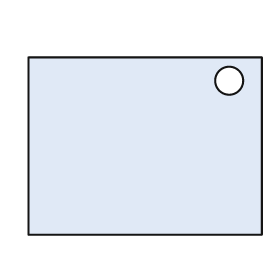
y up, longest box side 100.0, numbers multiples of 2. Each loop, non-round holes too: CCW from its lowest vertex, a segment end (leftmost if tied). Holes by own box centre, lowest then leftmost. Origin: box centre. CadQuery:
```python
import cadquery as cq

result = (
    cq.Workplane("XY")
    .moveTo(-50.0, -38.0)
    .lineTo(50.0, -38.0)
    .lineTo(50.0, 38.0)
    .lineTo(-50.0, 38.0)
    .close()
    .moveTo(36.0, 28.0)
    .circle(6.0)
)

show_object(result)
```